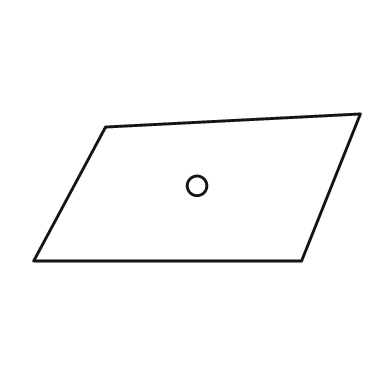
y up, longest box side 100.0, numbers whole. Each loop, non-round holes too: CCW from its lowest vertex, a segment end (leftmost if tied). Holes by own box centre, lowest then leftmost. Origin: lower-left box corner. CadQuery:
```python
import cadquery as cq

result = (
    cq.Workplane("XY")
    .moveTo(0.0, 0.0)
    .lineTo(82.0, 0.0)
    .lineTo(100.0, 45.0)
    .lineTo(22.0, 41.0)
    .close()
    .moveTo(50.0, 23.0)
    .circle(3.0)
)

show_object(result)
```